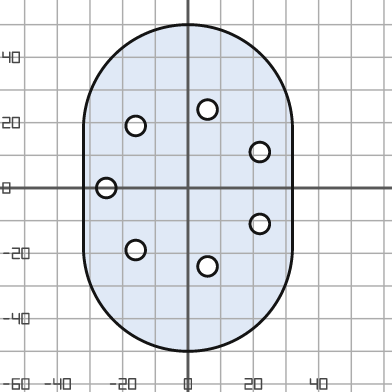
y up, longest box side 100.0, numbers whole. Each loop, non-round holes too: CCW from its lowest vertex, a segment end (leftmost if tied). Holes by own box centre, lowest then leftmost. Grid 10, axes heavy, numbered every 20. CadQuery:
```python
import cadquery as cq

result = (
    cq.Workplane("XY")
    .moveTo(-32.0, -18.0)
    .threePointArc((0.0, -50.0), (32.0, -18.0))
    .lineTo(32.0, 18.0)
    .threePointArc((0.0, 50.0), (-32.0, 18.0))
    .close()
    .moveTo(6.0, -24.0)
    .circle(3.0)
    .moveTo(-16.0, -19.0)
    .circle(3.0)
    .moveTo(22.0, -11.0)
    .circle(3.0)
    .moveTo(-25.0, 0.0)
    .circle(3.0)
    .moveTo(22.0, 11.0)
    .circle(3.0)
    .moveTo(-16.0, 19.0)
    .circle(3.0)
    .moveTo(6.0, 24.0)
    .circle(3.0)
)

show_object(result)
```